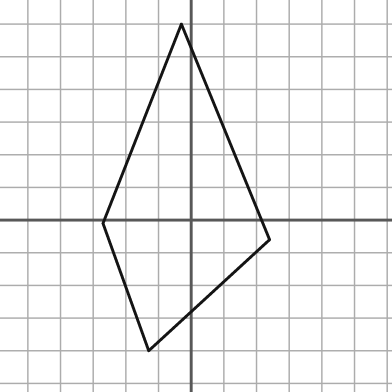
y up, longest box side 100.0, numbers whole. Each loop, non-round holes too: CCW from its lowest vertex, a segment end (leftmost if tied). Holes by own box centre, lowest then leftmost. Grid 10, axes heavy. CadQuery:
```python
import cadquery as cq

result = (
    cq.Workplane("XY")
    .moveTo(-13.0, -40.0)
    .lineTo(24.0, -6.0)
    .lineTo(-3.0, 60.0)
    .lineTo(-27.0, -1.0)
    .close()
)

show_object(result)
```